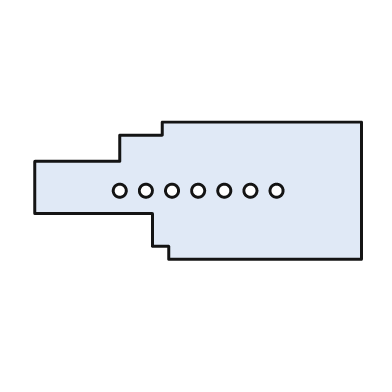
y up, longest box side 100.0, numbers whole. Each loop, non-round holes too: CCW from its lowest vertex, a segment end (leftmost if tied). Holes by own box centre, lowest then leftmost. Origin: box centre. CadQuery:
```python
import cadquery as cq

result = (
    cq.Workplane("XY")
    .moveTo(-9.0, -21.0)
    .lineTo(50.0, -21.0)
    .lineTo(50.0, 21.0)
    .lineTo(-11.0, 21.0)
    .lineTo(-11.0, 17.0)
    .lineTo(-24.0, 17.0)
    .lineTo(-24.0, 9.0)
    .lineTo(-50.0, 9.0)
    .lineTo(-50.0, -7.0)
    .lineTo(-14.0, -7.0)
    .lineTo(-14.0, -17.0)
    .lineTo(-9.0, -17.0)
    .close()
    .moveTo(-24.0, 0.0)
    .circle(2.0)
    .moveTo(-16.0, 0.0)
    .circle(2.0)
    .moveTo(-8.0, 0.0)
    .circle(2.0)
    .moveTo(0.0, 0.0)
    .circle(2.0)
    .moveTo(8.0, 0.0)
    .circle(2.0)
    .moveTo(16.0, 0.0)
    .circle(2.0)
    .moveTo(24.0, 0.0)
    .circle(2.0)
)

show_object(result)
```